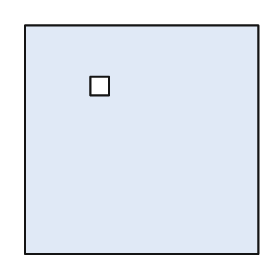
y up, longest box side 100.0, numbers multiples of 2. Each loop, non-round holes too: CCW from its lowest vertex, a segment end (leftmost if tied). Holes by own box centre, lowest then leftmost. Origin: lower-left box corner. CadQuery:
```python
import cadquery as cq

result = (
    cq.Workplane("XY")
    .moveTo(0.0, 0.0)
    .lineTo(100.0, 0.0)
    .lineTo(100.0, 98.0)
    .lineTo(0.0, 98.0)
    .close()
    .moveTo(28.0, 68.0)
    .lineTo(36.0, 68.0)
    .lineTo(36.0, 76.0)
    .lineTo(28.0, 76.0)
    .close()
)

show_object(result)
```